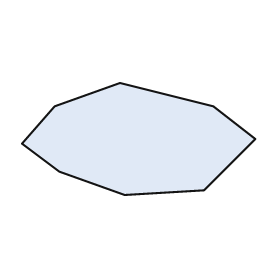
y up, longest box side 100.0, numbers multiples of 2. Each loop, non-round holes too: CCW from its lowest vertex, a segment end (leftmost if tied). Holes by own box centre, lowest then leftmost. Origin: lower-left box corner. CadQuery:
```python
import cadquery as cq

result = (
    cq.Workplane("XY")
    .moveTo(44.0, 0.0)
    .lineTo(78.0, 2.0)
    .lineTo(100.0, 24.0)
    .lineTo(82.0, 38.0)
    .lineTo(42.0, 48.0)
    .lineTo(14.0, 38.0)
    .lineTo(0.0, 22.0)
    .lineTo(16.0, 10.0)
    .close()
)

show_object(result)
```